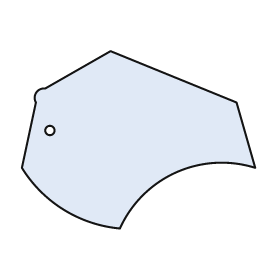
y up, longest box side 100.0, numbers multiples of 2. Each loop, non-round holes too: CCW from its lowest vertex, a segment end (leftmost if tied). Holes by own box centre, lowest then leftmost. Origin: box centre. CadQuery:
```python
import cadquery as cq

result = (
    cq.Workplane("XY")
    .moveTo(-8.0, -38.0)
    .threePointArc((16.0, -14.0), (50.0, -12.0))
    .lineTo(42.0, 16.0)
    .lineTo(-12.0, 38.0)
    .lineTo(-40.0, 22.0)
    .threePointArc((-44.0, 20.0), (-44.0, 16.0))
    .lineTo(-50.0, -12.0)
    .threePointArc((-32.0, -30.0), (-8.0, -38.0))
    .close()
    .moveTo(-38.0, 4.0)
    .circle(2.0)
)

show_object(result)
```